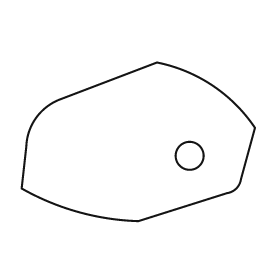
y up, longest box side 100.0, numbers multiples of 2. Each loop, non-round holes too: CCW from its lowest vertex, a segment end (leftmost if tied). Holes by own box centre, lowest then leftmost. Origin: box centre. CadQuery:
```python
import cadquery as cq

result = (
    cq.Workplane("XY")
    .moveTo(0.0, -34.0)
    .lineTo(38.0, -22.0)
    .threePointArc((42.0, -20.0), (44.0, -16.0))
    .lineTo(50.0, 6.0)
    .threePointArc((32.0, 24.0), (8.0, 34.0))
    .lineTo(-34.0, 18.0)
    .threePointArc((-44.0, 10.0), (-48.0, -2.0))
    .lineTo(-50.0, -20.0)
    .threePointArc((-26.0, -30.0), (0.0, -34.0))
    .close()
    .moveTo(22.0, -6.0)
    .circle(6.0)
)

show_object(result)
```